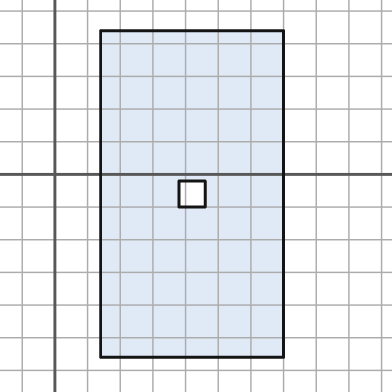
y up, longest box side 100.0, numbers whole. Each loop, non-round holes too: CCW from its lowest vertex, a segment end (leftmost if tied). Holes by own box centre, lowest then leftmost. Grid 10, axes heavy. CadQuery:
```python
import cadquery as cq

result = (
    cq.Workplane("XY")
    .moveTo(14.0, -56.0)
    .lineTo(70.0, -56.0)
    .lineTo(70.0, 44.0)
    .lineTo(14.0, 44.0)
    .close()
    .moveTo(38.0, -10.0)
    .lineTo(46.0, -10.0)
    .lineTo(46.0, -2.0)
    .lineTo(38.0, -2.0)
    .close()
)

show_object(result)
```